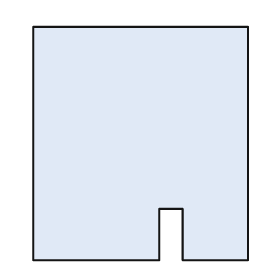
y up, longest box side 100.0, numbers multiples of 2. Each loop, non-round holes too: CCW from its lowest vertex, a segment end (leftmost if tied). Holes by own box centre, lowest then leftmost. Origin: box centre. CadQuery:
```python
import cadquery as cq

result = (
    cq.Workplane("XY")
    .moveTo(-46.0, -50.0)
    .lineTo(8.0, -50.0)
    .lineTo(8.0, -28.0)
    .lineTo(18.0, -28.0)
    .lineTo(18.0, -50.0)
    .lineTo(46.0, -50.0)
    .lineTo(46.0, 50.0)
    .lineTo(-46.0, 50.0)
    .close()
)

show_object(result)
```